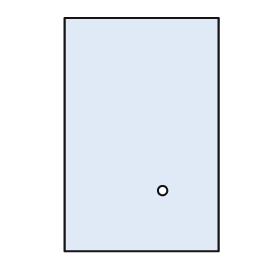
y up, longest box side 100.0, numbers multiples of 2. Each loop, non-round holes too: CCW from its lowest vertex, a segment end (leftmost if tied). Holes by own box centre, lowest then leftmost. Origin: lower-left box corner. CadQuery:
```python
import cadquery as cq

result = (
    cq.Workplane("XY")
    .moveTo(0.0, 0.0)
    .lineTo(66.0, 0.0)
    .lineTo(66.0, 100.0)
    .lineTo(0.0, 100.0)
    .close()
    .moveTo(42.0, 26.0)
    .circle(2.0)
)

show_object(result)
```